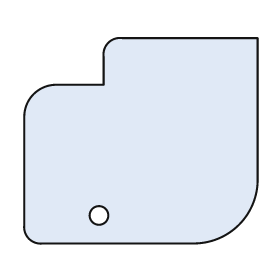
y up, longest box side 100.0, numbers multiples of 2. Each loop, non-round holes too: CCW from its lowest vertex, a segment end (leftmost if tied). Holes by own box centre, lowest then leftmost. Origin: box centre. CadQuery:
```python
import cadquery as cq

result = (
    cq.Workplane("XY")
    .moveTo(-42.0, -44.0)
    .lineTo(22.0, -44.0)
    .threePointArc((42.0, -36.0), (50.0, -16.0))
    .lineTo(50.0, 44.0)
    .lineTo(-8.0, 44.0)
    .threePointArc((-14.0, 42.0), (-16.0, 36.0))
    .lineTo(-16.0, 24.0)
    .lineTo(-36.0, 24.0)
    .threePointArc((-46.0, 20.0), (-50.0, 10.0))
    .lineTo(-50.0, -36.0)
    .threePointArc((-48.0, -42.0), (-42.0, -44.0))
    .close()
    .moveTo(-18.0, -32.0)
    .circle(4.0)
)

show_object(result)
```